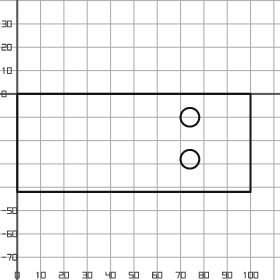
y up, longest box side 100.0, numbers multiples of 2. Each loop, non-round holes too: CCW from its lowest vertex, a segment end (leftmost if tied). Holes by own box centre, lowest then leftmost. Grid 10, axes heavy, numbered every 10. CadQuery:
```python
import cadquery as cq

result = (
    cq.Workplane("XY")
    .moveTo(0.0, -42.0)
    .lineTo(100.0, -42.0)
    .lineTo(100.0, 0.0)
    .lineTo(0.0, 0.0)
    .close()
    .moveTo(74.0, -28.0)
    .circle(4.0)
    .moveTo(74.0, -10.0)
    .circle(4.0)
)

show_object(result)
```